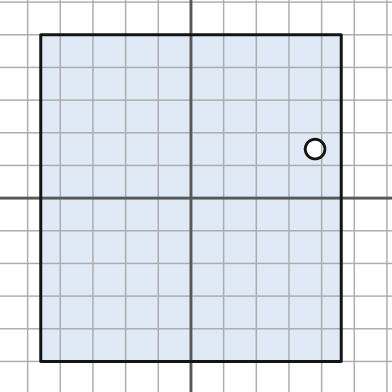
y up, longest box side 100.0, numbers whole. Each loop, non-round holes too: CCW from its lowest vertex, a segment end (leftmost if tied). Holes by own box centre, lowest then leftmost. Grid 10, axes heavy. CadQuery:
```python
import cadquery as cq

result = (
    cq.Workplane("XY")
    .moveTo(-46.0, -50.0)
    .lineTo(46.0, -50.0)
    .lineTo(46.0, 50.0)
    .lineTo(-46.0, 50.0)
    .close()
    .moveTo(38.0, 15.0)
    .circle(3.0)
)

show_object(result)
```